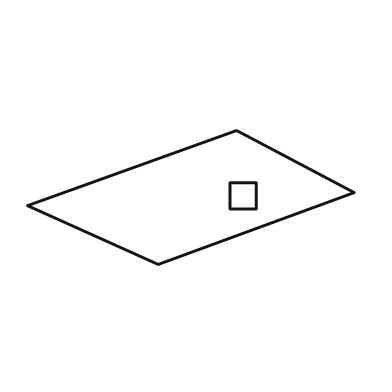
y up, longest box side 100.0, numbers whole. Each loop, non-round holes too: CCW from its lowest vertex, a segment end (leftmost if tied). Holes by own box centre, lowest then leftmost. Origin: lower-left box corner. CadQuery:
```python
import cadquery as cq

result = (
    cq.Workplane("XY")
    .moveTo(40.0, 0.0)
    .lineTo(100.0, 22.0)
    .lineTo(64.0, 41.0)
    .lineTo(0.0, 18.0)
    .close()
    .moveTo(62.0, 17.0)
    .lineTo(70.0, 17.0)
    .lineTo(70.0, 25.0)
    .lineTo(62.0, 25.0)
    .close()
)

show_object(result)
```